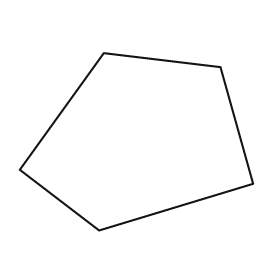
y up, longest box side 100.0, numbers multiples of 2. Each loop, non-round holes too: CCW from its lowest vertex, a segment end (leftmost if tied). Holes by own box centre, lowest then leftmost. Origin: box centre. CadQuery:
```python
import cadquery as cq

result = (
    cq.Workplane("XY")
    .moveTo(-16.0, -38.0)
    .lineTo(50.0, -18.0)
    .lineTo(36.0, 32.0)
    .lineTo(-14.0, 38.0)
    .lineTo(-50.0, -12.0)
    .close()
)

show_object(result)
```